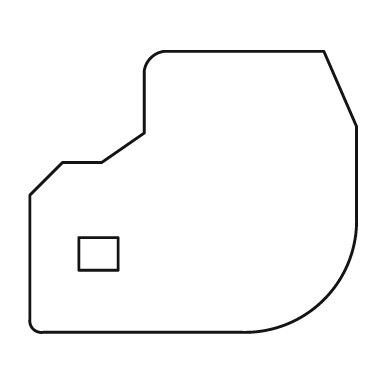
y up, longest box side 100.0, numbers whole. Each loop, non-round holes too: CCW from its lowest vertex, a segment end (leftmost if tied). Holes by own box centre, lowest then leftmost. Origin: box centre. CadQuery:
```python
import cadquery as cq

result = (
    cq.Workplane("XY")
    .moveTo(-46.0, -43.0)
    .lineTo(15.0, -43.0)
    .threePointArc((40.0, -33.0), (50.0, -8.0))
    .lineTo(50.0, 20.0)
    .lineTo(40.0, 43.0)
    .lineTo(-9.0, 43.0)
    .threePointArc((-13.0, 41.0), (-15.0, 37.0))
    .lineTo(-15.0, 18.0)
    .lineTo(-28.0, 9.0)
    .lineTo(-40.0, 9.0)
    .lineTo(-50.0, -1.0)
    .lineTo(-50.0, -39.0)
    .threePointArc((-49.0, -42.0), (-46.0, -43.0))
    .close()
    .moveTo(-35.0, -24.0)
    .lineTo(-23.0, -24.0)
    .lineTo(-23.0, -14.0)
    .lineTo(-35.0, -14.0)
    .close()
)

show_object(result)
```